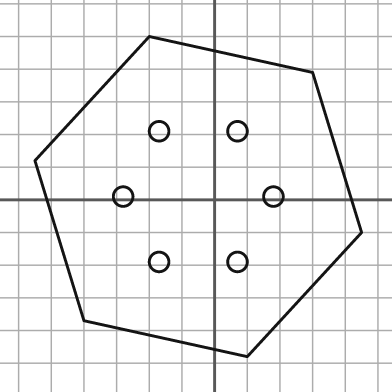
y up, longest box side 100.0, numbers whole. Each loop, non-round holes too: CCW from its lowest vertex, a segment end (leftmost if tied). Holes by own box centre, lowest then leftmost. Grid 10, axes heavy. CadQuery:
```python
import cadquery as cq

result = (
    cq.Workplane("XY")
    .moveTo(10.0, -48.0)
    .lineTo(45.0, -10.0)
    .lineTo(30.0, 39.0)
    .lineTo(-20.0, 50.0)
    .lineTo(-55.0, 12.0)
    .lineTo(-40.0, -37.0)
    .close()
    .moveTo(-17.0, -19.0)
    .circle(3.0)
    .moveTo(7.0, -19.0)
    .circle(3.0)
    .moveTo(-28.0, 1.0)
    .circle(3.0)
    .moveTo(18.0, 1.0)
    .circle(3.0)
    .moveTo(-17.0, 21.0)
    .circle(3.0)
    .moveTo(7.0, 21.0)
    .circle(3.0)
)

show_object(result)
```